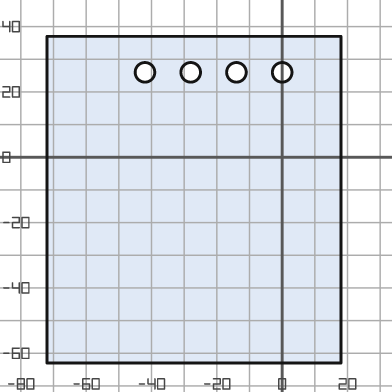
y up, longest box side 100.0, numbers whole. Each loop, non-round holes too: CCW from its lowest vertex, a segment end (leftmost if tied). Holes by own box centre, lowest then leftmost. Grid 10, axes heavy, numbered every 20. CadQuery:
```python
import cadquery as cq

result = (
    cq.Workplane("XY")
    .moveTo(-72.0, -63.0)
    .lineTo(18.0, -63.0)
    .lineTo(18.0, 37.0)
    .lineTo(-72.0, 37.0)
    .close()
    .moveTo(-42.0, 26.0)
    .circle(3.0)
    .moveTo(-28.0, 26.0)
    .circle(3.0)
    .moveTo(-14.0, 26.0)
    .circle(3.0)
    .moveTo(0.0, 26.0)
    .circle(3.0)
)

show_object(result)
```